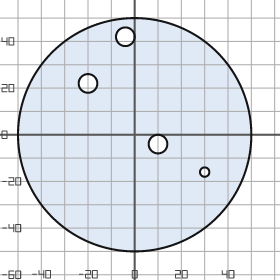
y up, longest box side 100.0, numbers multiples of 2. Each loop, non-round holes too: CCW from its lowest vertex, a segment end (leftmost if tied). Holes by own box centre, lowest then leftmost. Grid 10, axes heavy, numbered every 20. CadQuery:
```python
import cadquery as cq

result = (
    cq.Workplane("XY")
    .moveTo(0.0, 0.0)
    .circle(50.0)
    .moveTo(30.0, -16.0)
    .circle(2.0)
    .moveTo(10.0, -4.0)
    .circle(4.0)
    .moveTo(-20.0, 22.0)
    .circle(4.0)
    .moveTo(-4.0, 42.0)
    .circle(4.0)
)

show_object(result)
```